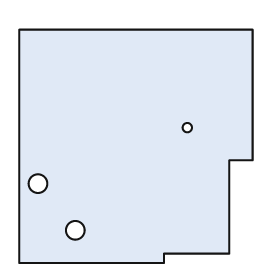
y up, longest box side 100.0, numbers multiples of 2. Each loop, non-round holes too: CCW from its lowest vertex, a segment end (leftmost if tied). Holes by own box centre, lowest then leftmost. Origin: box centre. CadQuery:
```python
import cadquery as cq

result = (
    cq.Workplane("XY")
    .moveTo(-50.0, -50.0)
    .lineTo(12.0, -50.0)
    .lineTo(12.0, -46.0)
    .lineTo(40.0, -46.0)
    .lineTo(40.0, -6.0)
    .lineTo(50.0, -6.0)
    .lineTo(50.0, 50.0)
    .lineTo(-50.0, 50.0)
    .close()
    .moveTo(-26.0, -36.0)
    .circle(4.0)
    .moveTo(-42.0, -16.0)
    .circle(4.0)
    .moveTo(22.0, 8.0)
    .circle(2.0)
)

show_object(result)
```